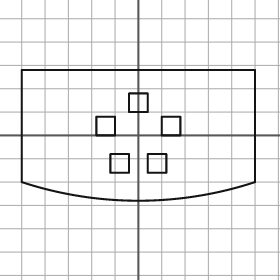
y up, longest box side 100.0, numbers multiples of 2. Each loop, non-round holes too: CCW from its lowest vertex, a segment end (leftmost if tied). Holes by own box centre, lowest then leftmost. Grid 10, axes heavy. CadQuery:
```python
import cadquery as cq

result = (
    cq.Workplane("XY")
    .moveTo(-50.0, -20.0)
    .threePointArc((0.0, -28.0), (50.0, -20.0))
    .lineTo(50.0, 28.0)
    .lineTo(-50.0, 28.0)
    .close()
    .moveTo(-12.0, -16.0)
    .lineTo(-4.0, -16.0)
    .lineTo(-4.0, -8.0)
    .lineTo(-12.0, -8.0)
    .close()
    .moveTo(4.0, -16.0)
    .lineTo(12.0, -16.0)
    .lineTo(12.0, -8.0)
    .lineTo(4.0, -8.0)
    .close()
    .moveTo(-18.0, 0.0)
    .lineTo(-10.0, 0.0)
    .lineTo(-10.0, 8.0)
    .lineTo(-18.0, 8.0)
    .close()
    .moveTo(10.0, 0.0)
    .lineTo(18.0, 0.0)
    .lineTo(18.0, 8.0)
    .lineTo(10.0, 8.0)
    .close()
    .moveTo(-4.0, 10.0)
    .lineTo(4.0, 10.0)
    .lineTo(4.0, 18.0)
    .lineTo(-4.0, 18.0)
    .close()
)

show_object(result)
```